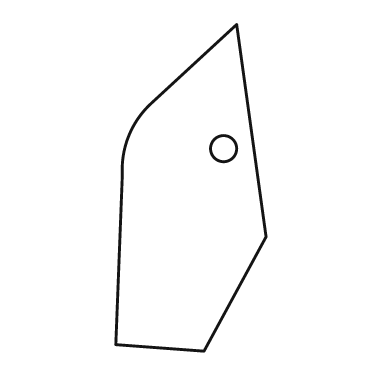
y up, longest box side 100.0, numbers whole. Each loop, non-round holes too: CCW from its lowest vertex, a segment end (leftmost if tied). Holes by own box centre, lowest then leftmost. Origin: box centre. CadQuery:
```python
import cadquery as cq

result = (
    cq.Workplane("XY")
    .moveTo(4.0, -50.0)
    .lineTo(23.0, -15.0)
    .lineTo(14.0, 50.0)
    .lineTo(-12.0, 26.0)
    .threePointArc((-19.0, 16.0), (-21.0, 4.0))
    .lineTo(-23.0, -48.0)
    .close()
    .moveTo(10.0, 12.0)
    .circle(4.0)
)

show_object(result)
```